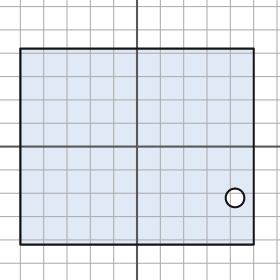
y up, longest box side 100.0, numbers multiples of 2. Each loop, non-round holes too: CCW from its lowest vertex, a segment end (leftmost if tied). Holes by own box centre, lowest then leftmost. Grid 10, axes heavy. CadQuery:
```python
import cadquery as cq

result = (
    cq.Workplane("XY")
    .moveTo(-50.0, -42.0)
    .lineTo(50.0, -42.0)
    .lineTo(50.0, 42.0)
    .lineTo(-50.0, 42.0)
    .close()
    .moveTo(42.0, -22.0)
    .circle(4.0)
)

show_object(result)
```